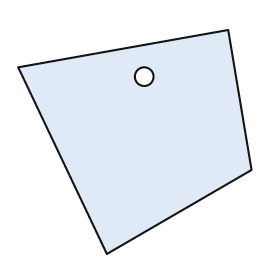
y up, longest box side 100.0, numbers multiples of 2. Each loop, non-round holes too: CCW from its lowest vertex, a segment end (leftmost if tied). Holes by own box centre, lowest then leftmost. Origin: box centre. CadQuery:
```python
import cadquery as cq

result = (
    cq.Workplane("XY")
    .moveTo(-12.0, -48.0)
    .lineTo(50.0, -12.0)
    .lineTo(40.0, 48.0)
    .lineTo(-50.0, 32.0)
    .close()
    .moveTo(4.0, 28.0)
    .circle(4.0)
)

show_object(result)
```